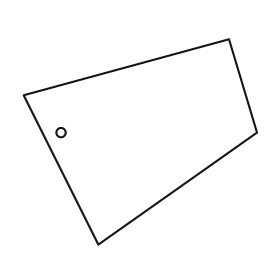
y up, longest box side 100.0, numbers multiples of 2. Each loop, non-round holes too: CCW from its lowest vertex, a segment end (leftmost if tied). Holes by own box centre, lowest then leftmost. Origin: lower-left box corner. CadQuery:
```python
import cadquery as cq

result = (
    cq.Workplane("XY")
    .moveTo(32.0, 0.0)
    .lineTo(100.0, 48.0)
    .lineTo(88.0, 88.0)
    .lineTo(0.0, 64.0)
    .close()
    .moveTo(16.0, 48.0)
    .circle(2.0)
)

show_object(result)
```